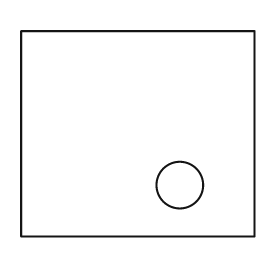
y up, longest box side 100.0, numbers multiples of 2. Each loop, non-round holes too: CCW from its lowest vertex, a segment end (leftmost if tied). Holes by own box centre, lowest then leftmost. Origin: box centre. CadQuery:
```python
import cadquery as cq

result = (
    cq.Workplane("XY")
    .moveTo(-50.0, -44.0)
    .lineTo(50.0, -44.0)
    .lineTo(50.0, 44.0)
    .lineTo(-50.0, 44.0)
    .close()
    .moveTo(18.0, -22.0)
    .circle(10.0)
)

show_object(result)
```